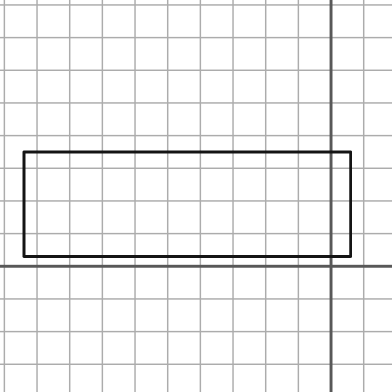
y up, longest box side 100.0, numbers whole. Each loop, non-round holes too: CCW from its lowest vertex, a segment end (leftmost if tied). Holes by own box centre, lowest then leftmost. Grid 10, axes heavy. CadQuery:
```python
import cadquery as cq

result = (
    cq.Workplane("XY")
    .moveTo(-94.0, 3.0)
    .lineTo(6.0, 3.0)
    .lineTo(6.0, 35.0)
    .lineTo(-94.0, 35.0)
    .close()
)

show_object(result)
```